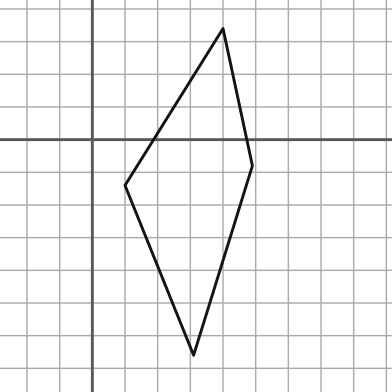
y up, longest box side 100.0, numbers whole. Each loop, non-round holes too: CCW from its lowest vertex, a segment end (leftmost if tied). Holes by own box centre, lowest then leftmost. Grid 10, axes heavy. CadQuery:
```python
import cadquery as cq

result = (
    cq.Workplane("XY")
    .moveTo(31.0, -66.0)
    .lineTo(49.0, -8.0)
    .lineTo(40.0, 34.0)
    .lineTo(10.0, -14.0)
    .close()
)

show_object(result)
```